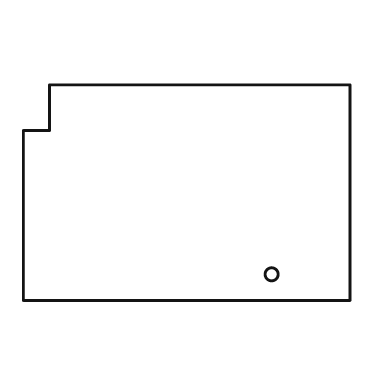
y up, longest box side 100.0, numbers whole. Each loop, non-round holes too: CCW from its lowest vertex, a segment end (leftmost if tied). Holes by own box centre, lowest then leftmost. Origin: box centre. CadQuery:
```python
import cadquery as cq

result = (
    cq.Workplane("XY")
    .moveTo(-50.0, -33.0)
    .lineTo(50.0, -33.0)
    .lineTo(50.0, 33.0)
    .lineTo(-42.0, 33.0)
    .lineTo(-42.0, 19.0)
    .lineTo(-50.0, 19.0)
    .close()
    .moveTo(26.0, -25.0)
    .circle(2.0)
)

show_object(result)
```